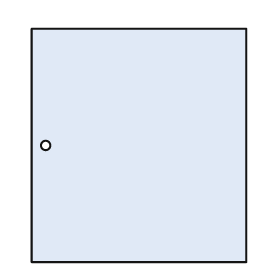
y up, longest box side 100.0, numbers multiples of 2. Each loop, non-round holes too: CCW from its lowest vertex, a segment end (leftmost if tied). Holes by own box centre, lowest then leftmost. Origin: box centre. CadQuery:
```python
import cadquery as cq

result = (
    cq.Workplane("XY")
    .moveTo(-46.0, -50.0)
    .lineTo(46.0, -50.0)
    .lineTo(46.0, 50.0)
    .lineTo(-46.0, 50.0)
    .close()
    .moveTo(-40.0, 0.0)
    .circle(2.0)
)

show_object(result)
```